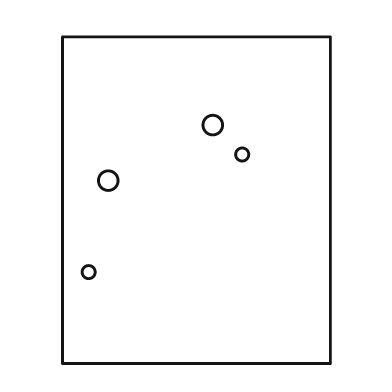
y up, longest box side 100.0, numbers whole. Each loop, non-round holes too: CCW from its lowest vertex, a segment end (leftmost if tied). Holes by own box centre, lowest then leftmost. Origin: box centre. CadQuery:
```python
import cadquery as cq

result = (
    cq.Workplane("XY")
    .moveTo(-41.0, -50.0)
    .lineTo(41.0, -50.0)
    .lineTo(41.0, 50.0)
    .lineTo(-41.0, 50.0)
    .close()
    .moveTo(-33.0, -22.0)
    .circle(2.0)
    .moveTo(-27.0, 6.0)
    .circle(3.0)
    .moveTo(14.0, 14.0)
    .circle(2.0)
    .moveTo(5.0, 23.0)
    .circle(3.0)
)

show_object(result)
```